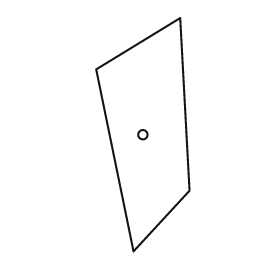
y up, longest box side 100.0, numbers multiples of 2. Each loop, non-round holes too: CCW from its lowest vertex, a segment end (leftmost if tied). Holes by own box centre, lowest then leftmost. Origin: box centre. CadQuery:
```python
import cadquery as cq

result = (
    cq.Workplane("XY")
    .moveTo(-4.0, -50.0)
    .lineTo(20.0, -24.0)
    .lineTo(16.0, 50.0)
    .lineTo(-20.0, 28.0)
    .close()
    .moveTo(0.0, 0.0)
    .circle(2.0)
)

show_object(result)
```